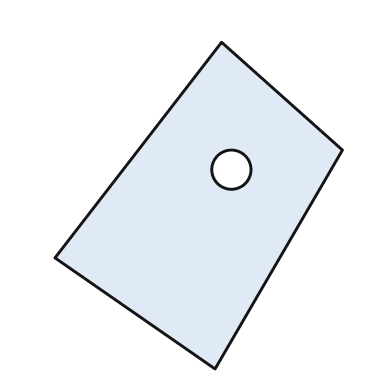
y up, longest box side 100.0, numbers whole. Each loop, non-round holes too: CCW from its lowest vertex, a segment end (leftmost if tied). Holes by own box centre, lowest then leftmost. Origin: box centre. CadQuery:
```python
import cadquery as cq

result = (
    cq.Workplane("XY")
    .moveTo(5.0, -50.0)
    .lineTo(44.0, 17.0)
    .lineTo(7.0, 50.0)
    .lineTo(-44.0, -16.0)
    .close()
    .moveTo(10.0, 11.0)
    .circle(6.0)
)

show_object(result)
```